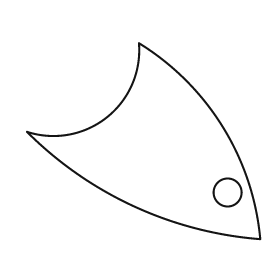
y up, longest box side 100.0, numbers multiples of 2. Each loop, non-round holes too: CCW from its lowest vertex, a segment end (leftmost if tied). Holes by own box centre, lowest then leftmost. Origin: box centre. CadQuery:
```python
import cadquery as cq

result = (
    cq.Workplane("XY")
    .moveTo(50.0, -42.0)
    .threePointArc((34.0, 6.0), (-2.0, 42.0))
    .threePointArc((-16.0, 10.0), (-50.0, 4.0))
    .threePointArc((-4.0, -28.0), (50.0, -42.0))
    .close()
    .moveTo(36.0, -22.0)
    .circle(6.0)
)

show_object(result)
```